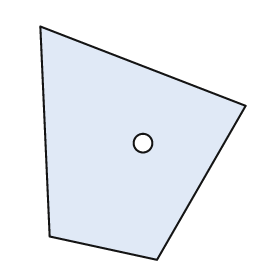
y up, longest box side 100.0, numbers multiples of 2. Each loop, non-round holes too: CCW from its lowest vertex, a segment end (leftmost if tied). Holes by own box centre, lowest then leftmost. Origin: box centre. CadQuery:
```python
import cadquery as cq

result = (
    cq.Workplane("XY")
    .moveTo(6.0, -50.0)
    .lineTo(44.0, 16.0)
    .lineTo(-44.0, 50.0)
    .lineTo(-40.0, -40.0)
    .close()
    .moveTo(0.0, 0.0)
    .circle(4.0)
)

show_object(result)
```